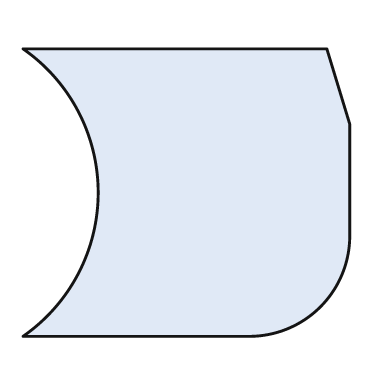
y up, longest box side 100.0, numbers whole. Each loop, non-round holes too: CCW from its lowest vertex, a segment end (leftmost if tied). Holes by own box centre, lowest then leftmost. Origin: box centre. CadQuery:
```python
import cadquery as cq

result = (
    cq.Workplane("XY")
    .moveTo(-50.0, -44.0)
    .lineTo(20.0, -44.0)
    .threePointArc((41.0, -35.0), (50.0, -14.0))
    .lineTo(50.0, 21.0)
    .lineTo(43.0, 44.0)
    .lineTo(-50.0, 44.0)
    .threePointArc((-27.0, 0.0), (-50.0, -44.0))
    .close()
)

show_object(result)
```